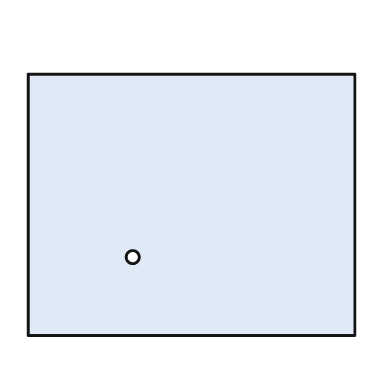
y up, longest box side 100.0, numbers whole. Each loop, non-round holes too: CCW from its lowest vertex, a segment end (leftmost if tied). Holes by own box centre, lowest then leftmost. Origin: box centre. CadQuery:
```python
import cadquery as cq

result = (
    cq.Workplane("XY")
    .moveTo(-50.0, -40.0)
    .lineTo(50.0, -40.0)
    .lineTo(50.0, 40.0)
    .lineTo(-50.0, 40.0)
    .close()
    .moveTo(-18.0, -16.0)
    .circle(2.0)
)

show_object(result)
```